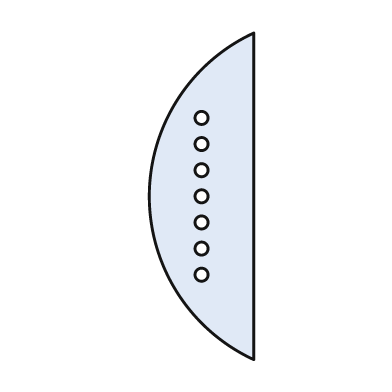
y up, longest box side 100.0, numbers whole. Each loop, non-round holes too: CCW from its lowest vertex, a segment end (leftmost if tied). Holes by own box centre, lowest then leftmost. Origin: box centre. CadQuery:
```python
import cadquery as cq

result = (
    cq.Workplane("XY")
    .moveTo(16.0, -50.0)
    .lineTo(16.0, 50.0)
    .threePointArc((-16.0, 0.0), (16.0, -50.0))
    .close()
    .moveTo(0.0, -24.0)
    .circle(2.0)
    .moveTo(0.0, -16.0)
    .circle(2.0)
    .moveTo(0.0, -8.0)
    .circle(2.0)
    .moveTo(0.0, 0.0)
    .circle(2.0)
    .moveTo(0.0, 8.0)
    .circle(2.0)
    .moveTo(0.0, 16.0)
    .circle(2.0)
    .moveTo(0.0, 24.0)
    .circle(2.0)
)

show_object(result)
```